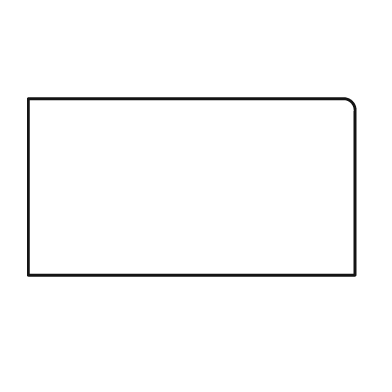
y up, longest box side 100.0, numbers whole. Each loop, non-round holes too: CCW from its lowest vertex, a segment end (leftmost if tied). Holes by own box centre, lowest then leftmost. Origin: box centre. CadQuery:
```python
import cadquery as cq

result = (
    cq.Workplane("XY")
    .moveTo(-50.0, -27.0)
    .lineTo(50.0, -27.0)
    .lineTo(50.0, 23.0)
    .threePointArc((49.0, 26.0), (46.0, 27.0))
    .lineTo(-50.0, 27.0)
    .close()
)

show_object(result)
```